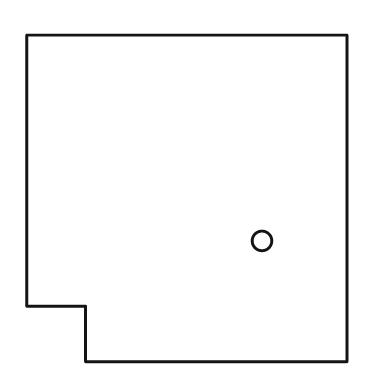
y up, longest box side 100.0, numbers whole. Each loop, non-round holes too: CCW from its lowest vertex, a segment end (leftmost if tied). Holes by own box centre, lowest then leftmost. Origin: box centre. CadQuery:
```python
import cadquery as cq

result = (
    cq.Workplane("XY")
    .moveTo(-31.0, -50.0)
    .lineTo(49.0, -50.0)
    .lineTo(49.0, 50.0)
    .lineTo(-49.0, 50.0)
    .lineTo(-49.0, -33.0)
    .lineTo(-31.0, -33.0)
    .close()
    .moveTo(23.0, -13.0)
    .circle(3.0)
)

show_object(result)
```